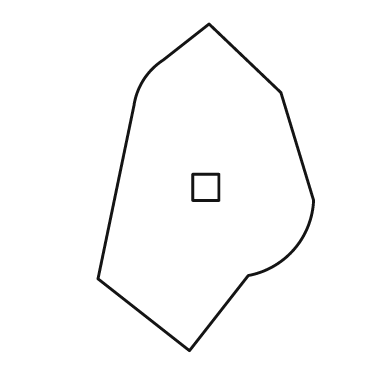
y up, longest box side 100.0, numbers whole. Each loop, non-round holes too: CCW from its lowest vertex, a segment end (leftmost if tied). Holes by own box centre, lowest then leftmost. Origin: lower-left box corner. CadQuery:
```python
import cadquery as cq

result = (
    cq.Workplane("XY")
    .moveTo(28.0, 0.0)
    .lineTo(46.0, 23.0)
    .threePointArc((60.0, 31.0), (66.0, 46.0))
    .lineTo(56.0, 79.0)
    .lineTo(34.0, 100.0)
    .lineTo(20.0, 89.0)
    .threePointArc((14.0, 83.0), (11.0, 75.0))
    .lineTo(0.0, 22.0)
    .close()
    .moveTo(29.0, 46.0)
    .lineTo(37.0, 46.0)
    .lineTo(37.0, 54.0)
    .lineTo(29.0, 54.0)
    .close()
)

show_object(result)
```